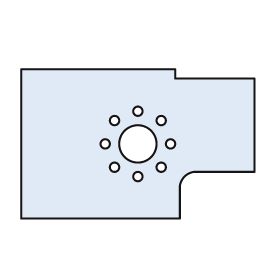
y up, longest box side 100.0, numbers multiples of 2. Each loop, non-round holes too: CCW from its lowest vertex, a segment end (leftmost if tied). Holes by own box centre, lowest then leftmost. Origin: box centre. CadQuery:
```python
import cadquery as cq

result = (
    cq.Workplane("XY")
    .moveTo(-50.0, -32.0)
    .lineTo(18.0, -32.0)
    .lineTo(18.0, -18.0)
    .threePointArc((20.0, -14.0), (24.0, -12.0))
    .lineTo(50.0, -12.0)
    .lineTo(50.0, 28.0)
    .lineTo(16.0, 28.0)
    .lineTo(16.0, 32.0)
    .lineTo(-50.0, 32.0)
    .close()
    .moveTo(0.0, -14.0)
    .circle(2.0)
    .moveTo(-10.0, -10.0)
    .circle(2.0)
    .moveTo(10.0, -10.0)
    .circle(2.0)
    .moveTo(-14.0, 0.0)
    .circle(2.0)
    .moveTo(0.0, 0.0)
    .circle(8.0)
    .moveTo(14.0, 0.0)
    .circle(2.0)
    .moveTo(-10.0, 10.0)
    .circle(2.0)
    .moveTo(10.0, 10.0)
    .circle(2.0)
    .moveTo(0.0, 14.0)
    .circle(2.0)
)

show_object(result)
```